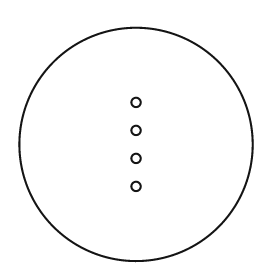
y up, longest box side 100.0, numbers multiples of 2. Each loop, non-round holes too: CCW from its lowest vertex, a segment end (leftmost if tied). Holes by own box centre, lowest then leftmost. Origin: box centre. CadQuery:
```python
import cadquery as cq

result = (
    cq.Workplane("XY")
    .moveTo(0.0, 0.0)
    .circle(50.0)
    .moveTo(0.0, -18.0)
    .circle(2.0)
    .moveTo(0.0, -6.0)
    .circle(2.0)
    .moveTo(0.0, 6.0)
    .circle(2.0)
    .moveTo(0.0, 18.0)
    .circle(2.0)
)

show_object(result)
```